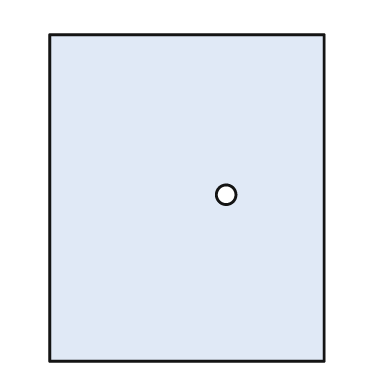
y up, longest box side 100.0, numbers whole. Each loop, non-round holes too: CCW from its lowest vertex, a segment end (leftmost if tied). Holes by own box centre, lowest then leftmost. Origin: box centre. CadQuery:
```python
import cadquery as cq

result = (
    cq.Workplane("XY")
    .moveTo(-42.0, -50.0)
    .lineTo(42.0, -50.0)
    .lineTo(42.0, 50.0)
    .lineTo(-42.0, 50.0)
    .close()
    .moveTo(12.0, 1.0)
    .circle(3.0)
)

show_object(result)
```